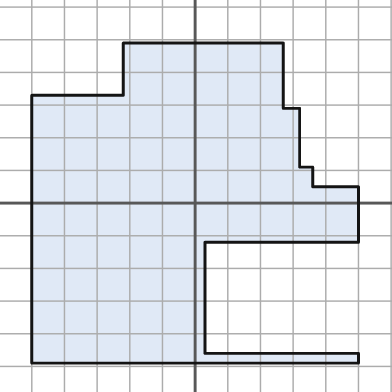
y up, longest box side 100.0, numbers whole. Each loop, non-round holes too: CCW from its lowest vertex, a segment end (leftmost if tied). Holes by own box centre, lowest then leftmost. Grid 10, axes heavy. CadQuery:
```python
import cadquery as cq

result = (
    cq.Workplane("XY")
    .moveTo(-50.0, -49.0)
    .lineTo(50.0, -49.0)
    .lineTo(50.0, -46.0)
    .lineTo(3.0, -46.0)
    .lineTo(3.0, -12.0)
    .lineTo(50.0, -12.0)
    .lineTo(50.0, 5.0)
    .lineTo(36.0, 5.0)
    .lineTo(36.0, 11.0)
    .lineTo(32.0, 11.0)
    .lineTo(32.0, 29.0)
    .lineTo(27.0, 29.0)
    .lineTo(27.0, 49.0)
    .lineTo(-22.0, 49.0)
    .lineTo(-22.0, 33.0)
    .lineTo(-50.0, 33.0)
    .close()
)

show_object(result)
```